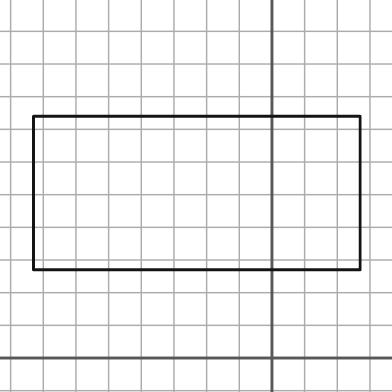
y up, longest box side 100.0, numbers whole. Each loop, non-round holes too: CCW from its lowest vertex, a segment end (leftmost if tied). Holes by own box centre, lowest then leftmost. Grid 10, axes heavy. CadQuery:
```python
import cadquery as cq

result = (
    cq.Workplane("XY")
    .moveTo(-73.0, 27.0)
    .lineTo(27.0, 27.0)
    .lineTo(27.0, 74.0)
    .lineTo(-73.0, 74.0)
    .close()
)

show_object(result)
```